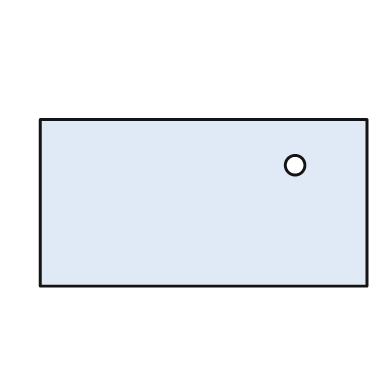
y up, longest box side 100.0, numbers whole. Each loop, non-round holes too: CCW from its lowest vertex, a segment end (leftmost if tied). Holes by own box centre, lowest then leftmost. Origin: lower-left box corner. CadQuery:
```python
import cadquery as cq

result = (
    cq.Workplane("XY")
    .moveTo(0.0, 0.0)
    .lineTo(100.0, 0.0)
    .lineTo(100.0, 51.0)
    .lineTo(0.0, 51.0)
    .close()
    .moveTo(78.0, 37.0)
    .circle(3.0)
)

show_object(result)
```